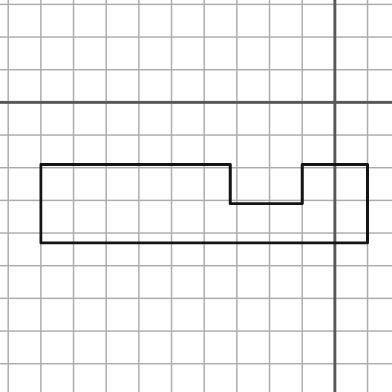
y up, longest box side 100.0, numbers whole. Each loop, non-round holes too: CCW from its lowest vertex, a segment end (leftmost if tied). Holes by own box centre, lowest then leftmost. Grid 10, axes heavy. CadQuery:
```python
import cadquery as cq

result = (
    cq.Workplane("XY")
    .moveTo(-90.0, -43.0)
    .lineTo(10.0, -43.0)
    .lineTo(10.0, -19.0)
    .lineTo(-10.0, -19.0)
    .lineTo(-10.0, -31.0)
    .lineTo(-32.0, -31.0)
    .lineTo(-32.0, -19.0)
    .lineTo(-90.0, -19.0)
    .close()
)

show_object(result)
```